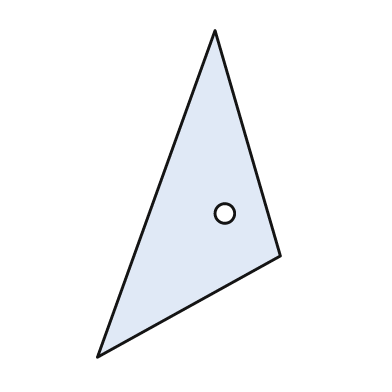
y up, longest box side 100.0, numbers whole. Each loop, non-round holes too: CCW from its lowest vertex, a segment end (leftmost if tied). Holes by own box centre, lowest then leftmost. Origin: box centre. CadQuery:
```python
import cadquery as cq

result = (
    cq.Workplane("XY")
    .moveTo(-28.0, -50.0)
    .lineTo(28.0, -19.0)
    .lineTo(8.0, 50.0)
    .close()
    .moveTo(11.0, -6.0)
    .circle(3.0)
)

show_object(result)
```